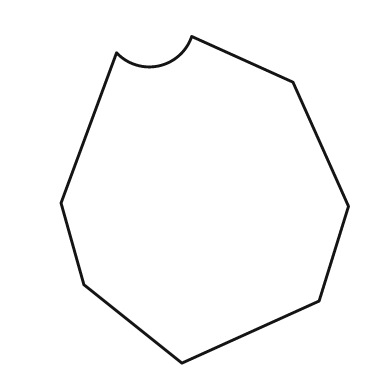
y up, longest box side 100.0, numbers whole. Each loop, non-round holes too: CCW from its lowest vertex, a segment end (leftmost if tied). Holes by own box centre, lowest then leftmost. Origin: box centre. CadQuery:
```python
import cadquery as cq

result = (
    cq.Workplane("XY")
    .moveTo(-7.0, -50.0)
    .lineTo(35.0, -31.0)
    .lineTo(44.0, -2.0)
    .lineTo(27.0, 36.0)
    .lineTo(-4.0, 50.0)
    .threePointArc((-14.0, 41.0), (-27.0, 45.0))
    .lineTo(-44.0, -1.0)
    .lineTo(-37.0, -26.0)
    .close()
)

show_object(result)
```